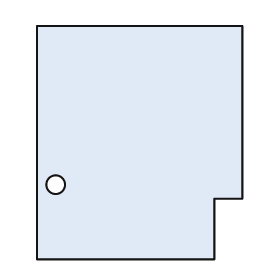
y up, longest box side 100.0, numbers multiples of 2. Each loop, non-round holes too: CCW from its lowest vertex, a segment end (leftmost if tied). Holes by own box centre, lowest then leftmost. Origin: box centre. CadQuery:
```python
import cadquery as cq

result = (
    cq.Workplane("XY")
    .moveTo(-44.0, -50.0)
    .lineTo(32.0, -50.0)
    .lineTo(32.0, -24.0)
    .lineTo(44.0, -24.0)
    .lineTo(44.0, 50.0)
    .lineTo(-44.0, 50.0)
    .close()
    .moveTo(-36.0, -18.0)
    .circle(4.0)
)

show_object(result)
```